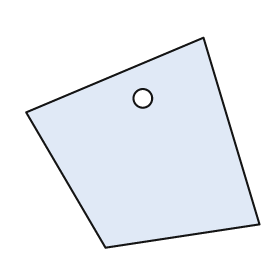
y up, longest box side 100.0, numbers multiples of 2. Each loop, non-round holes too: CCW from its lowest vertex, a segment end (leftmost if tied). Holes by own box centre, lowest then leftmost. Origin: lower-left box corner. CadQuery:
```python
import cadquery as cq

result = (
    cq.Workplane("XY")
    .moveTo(34.0, 0.0)
    .lineTo(100.0, 10.0)
    .lineTo(76.0, 90.0)
    .lineTo(0.0, 58.0)
    .close()
    .moveTo(50.0, 64.0)
    .circle(4.0)
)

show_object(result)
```